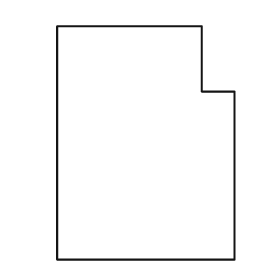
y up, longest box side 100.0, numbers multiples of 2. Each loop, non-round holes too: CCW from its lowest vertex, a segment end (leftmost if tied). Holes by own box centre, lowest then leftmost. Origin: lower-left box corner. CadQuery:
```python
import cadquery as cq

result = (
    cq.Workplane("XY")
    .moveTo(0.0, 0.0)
    .lineTo(76.0, 0.0)
    .lineTo(76.0, 72.0)
    .lineTo(62.0, 72.0)
    .lineTo(62.0, 100.0)
    .lineTo(0.0, 100.0)
    .close()
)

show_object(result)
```